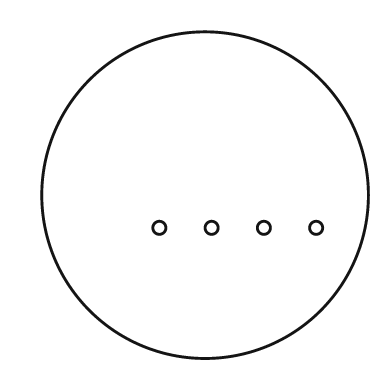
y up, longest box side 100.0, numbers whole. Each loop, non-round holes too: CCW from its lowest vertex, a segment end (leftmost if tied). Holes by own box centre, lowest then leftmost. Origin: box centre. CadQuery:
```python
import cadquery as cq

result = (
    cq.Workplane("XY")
    .moveTo(0.0, 0.0)
    .circle(50.0)
    .moveTo(-14.0, -10.0)
    .circle(2.0)
    .moveTo(2.0, -10.0)
    .circle(2.0)
    .moveTo(18.0, -10.0)
    .circle(2.0)
    .moveTo(34.0, -10.0)
    .circle(2.0)
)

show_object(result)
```